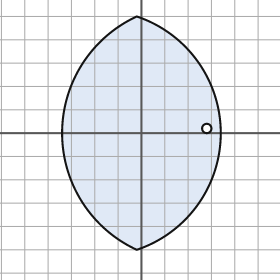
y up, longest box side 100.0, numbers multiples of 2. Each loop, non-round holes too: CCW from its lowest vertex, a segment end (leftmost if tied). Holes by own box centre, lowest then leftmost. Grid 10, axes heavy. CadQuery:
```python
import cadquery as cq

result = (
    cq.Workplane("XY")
    .moveTo(-2.0, -50.0)
    .threePointArc((34.0, 0.0), (-2.0, 50.0))
    .threePointArc((-34.0, 0.0), (-2.0, -50.0))
    .close()
    .moveTo(28.0, 2.0)
    .circle(2.0)
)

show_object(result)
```